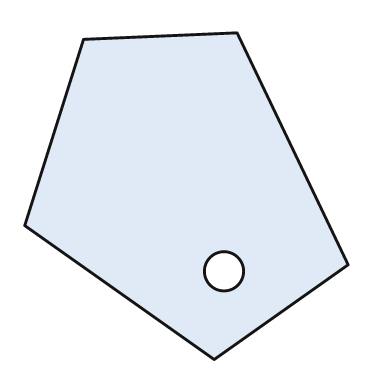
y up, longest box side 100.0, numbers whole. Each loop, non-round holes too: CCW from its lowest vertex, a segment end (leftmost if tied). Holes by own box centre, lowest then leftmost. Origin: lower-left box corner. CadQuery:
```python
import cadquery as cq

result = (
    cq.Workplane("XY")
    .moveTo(58.0, 0.0)
    .lineTo(99.0, 29.0)
    .lineTo(65.0, 100.0)
    .lineTo(18.0, 98.0)
    .lineTo(0.0, 41.0)
    .close()
    .moveTo(61.0, 27.0)
    .circle(6.0)
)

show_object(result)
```